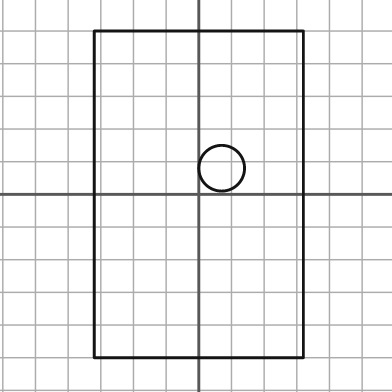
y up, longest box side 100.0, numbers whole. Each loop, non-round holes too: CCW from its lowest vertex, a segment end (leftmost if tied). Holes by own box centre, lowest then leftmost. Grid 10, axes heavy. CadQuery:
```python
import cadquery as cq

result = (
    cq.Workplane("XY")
    .moveTo(-32.0, -50.0)
    .lineTo(32.0, -50.0)
    .lineTo(32.0, 50.0)
    .lineTo(-32.0, 50.0)
    .close()
    .moveTo(7.0, 8.0)
    .circle(7.0)
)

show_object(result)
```